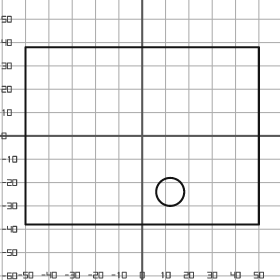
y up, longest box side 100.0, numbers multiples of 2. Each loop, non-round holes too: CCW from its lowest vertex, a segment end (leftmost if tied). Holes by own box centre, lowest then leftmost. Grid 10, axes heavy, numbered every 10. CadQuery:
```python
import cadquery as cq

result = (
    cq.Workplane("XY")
    .moveTo(-50.0, -38.0)
    .lineTo(50.0, -38.0)
    .lineTo(50.0, 38.0)
    .lineTo(-50.0, 38.0)
    .close()
    .moveTo(12.0, -24.0)
    .circle(6.0)
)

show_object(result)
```